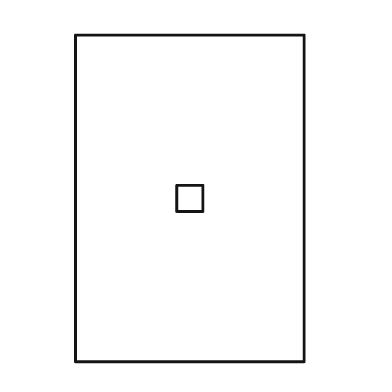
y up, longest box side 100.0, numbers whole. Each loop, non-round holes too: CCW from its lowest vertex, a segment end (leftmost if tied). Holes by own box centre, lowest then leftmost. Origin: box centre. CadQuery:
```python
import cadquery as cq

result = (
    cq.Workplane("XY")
    .moveTo(-35.0, -50.0)
    .lineTo(35.0, -50.0)
    .lineTo(35.0, 50.0)
    .lineTo(-35.0, 50.0)
    .close()
    .moveTo(-4.0, -4.0)
    .lineTo(4.0, -4.0)
    .lineTo(4.0, 4.0)
    .lineTo(-4.0, 4.0)
    .close()
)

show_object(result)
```